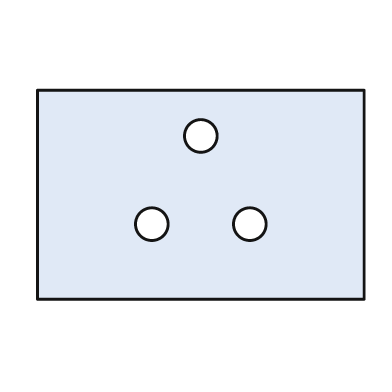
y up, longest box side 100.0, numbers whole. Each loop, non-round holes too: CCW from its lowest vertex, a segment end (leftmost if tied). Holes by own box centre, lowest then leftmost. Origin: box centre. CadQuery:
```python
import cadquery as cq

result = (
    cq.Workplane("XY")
    .moveTo(-50.0, -32.0)
    .lineTo(50.0, -32.0)
    .lineTo(50.0, 32.0)
    .lineTo(-50.0, 32.0)
    .close()
    .moveTo(-15.0, -9.0)
    .circle(5.0)
    .moveTo(15.0, -9.0)
    .circle(5.0)
    .moveTo(0.0, 18.0)
    .circle(5.0)
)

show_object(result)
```